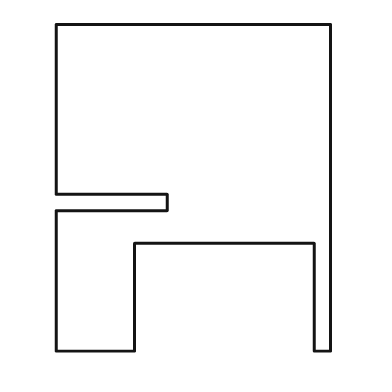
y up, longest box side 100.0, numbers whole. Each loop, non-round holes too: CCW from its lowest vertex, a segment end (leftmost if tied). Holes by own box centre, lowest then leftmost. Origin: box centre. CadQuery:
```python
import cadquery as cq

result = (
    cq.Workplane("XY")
    .moveTo(-42.0, -50.0)
    .lineTo(-18.0, -50.0)
    .lineTo(-18.0, -17.0)
    .lineTo(37.0, -17.0)
    .lineTo(37.0, -50.0)
    .lineTo(42.0, -50.0)
    .lineTo(42.0, 50.0)
    .lineTo(-42.0, 50.0)
    .lineTo(-42.0, -2.0)
    .lineTo(-8.0, -2.0)
    .lineTo(-8.0, -7.0)
    .lineTo(-42.0, -7.0)
    .close()
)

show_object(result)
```